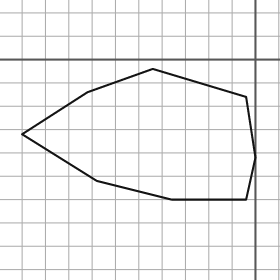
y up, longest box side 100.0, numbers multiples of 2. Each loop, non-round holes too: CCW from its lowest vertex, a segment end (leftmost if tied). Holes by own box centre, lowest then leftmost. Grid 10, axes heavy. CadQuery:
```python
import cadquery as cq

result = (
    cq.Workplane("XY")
    .moveTo(-36.0, -60.0)
    .lineTo(-4.0, -60.0)
    .lineTo(0.0, -42.0)
    .lineTo(-4.0, -16.0)
    .lineTo(-44.0, -4.0)
    .lineTo(-72.0, -14.0)
    .lineTo(-100.0, -32.0)
    .lineTo(-68.0, -52.0)
    .close()
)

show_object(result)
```